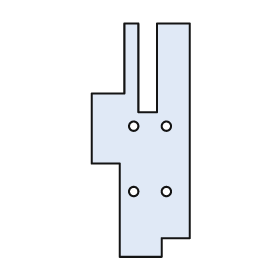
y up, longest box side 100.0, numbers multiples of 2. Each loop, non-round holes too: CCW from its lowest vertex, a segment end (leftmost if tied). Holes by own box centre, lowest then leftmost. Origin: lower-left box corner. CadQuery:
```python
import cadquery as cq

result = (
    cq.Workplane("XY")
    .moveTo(12.0, 0.0)
    .lineTo(30.0, 0.0)
    .lineTo(30.0, 8.0)
    .lineTo(42.0, 8.0)
    .lineTo(42.0, 100.0)
    .lineTo(28.0, 100.0)
    .lineTo(28.0, 62.0)
    .lineTo(20.0, 62.0)
    .lineTo(20.0, 100.0)
    .lineTo(14.0, 100.0)
    .lineTo(14.0, 70.0)
    .lineTo(0.0, 70.0)
    .lineTo(0.0, 40.0)
    .lineTo(12.0, 40.0)
    .close()
    .moveTo(18.0, 28.0)
    .circle(2.0)
    .moveTo(32.0, 28.0)
    .circle(2.0)
    .moveTo(18.0, 56.0)
    .circle(2.0)
    .moveTo(32.0, 56.0)
    .circle(2.0)
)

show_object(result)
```